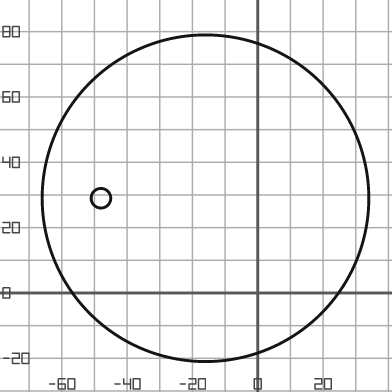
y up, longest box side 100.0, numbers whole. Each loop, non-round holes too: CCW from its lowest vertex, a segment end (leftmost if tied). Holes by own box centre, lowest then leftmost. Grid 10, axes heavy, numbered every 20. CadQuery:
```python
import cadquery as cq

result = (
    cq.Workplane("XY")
    .moveTo(-16.0, 29.0)
    .circle(50.0)
    .moveTo(-48.0, 29.0)
    .circle(3.0)
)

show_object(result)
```